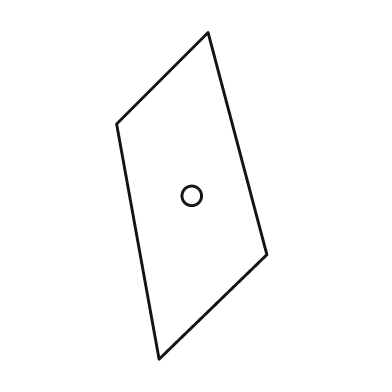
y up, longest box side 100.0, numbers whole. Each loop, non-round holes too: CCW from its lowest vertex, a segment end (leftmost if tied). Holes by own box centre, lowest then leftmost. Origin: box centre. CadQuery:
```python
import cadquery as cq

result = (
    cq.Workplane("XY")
    .moveTo(-10.0, -50.0)
    .lineTo(23.0, -18.0)
    .lineTo(5.0, 50.0)
    .lineTo(-23.0, 22.0)
    .close()
    .moveTo(0.0, 0.0)
    .circle(3.0)
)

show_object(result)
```